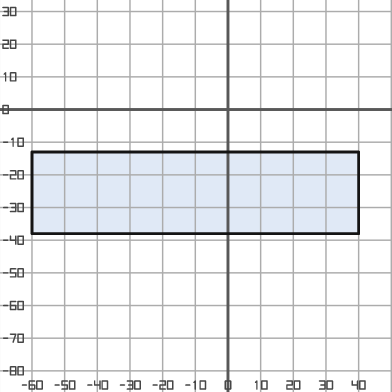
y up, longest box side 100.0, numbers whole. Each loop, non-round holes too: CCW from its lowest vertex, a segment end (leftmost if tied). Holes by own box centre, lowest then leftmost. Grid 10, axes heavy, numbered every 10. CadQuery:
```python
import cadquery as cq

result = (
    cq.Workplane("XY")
    .moveTo(-60.0, -38.0)
    .lineTo(40.0, -38.0)
    .lineTo(40.0, -13.0)
    .lineTo(-60.0, -13.0)
    .close()
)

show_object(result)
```